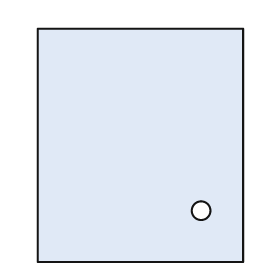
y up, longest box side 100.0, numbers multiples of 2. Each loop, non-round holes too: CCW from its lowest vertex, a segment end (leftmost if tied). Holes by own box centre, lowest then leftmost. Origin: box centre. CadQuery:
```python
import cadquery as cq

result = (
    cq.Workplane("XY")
    .moveTo(-44.0, -50.0)
    .lineTo(44.0, -50.0)
    .lineTo(44.0, 50.0)
    .lineTo(-44.0, 50.0)
    .close()
    .moveTo(26.0, -28.0)
    .circle(4.0)
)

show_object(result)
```